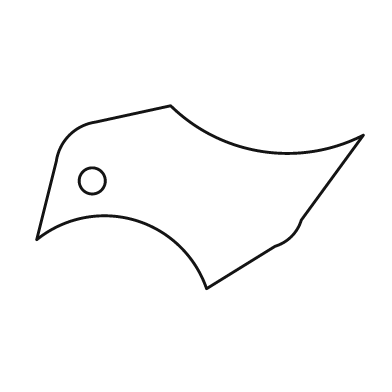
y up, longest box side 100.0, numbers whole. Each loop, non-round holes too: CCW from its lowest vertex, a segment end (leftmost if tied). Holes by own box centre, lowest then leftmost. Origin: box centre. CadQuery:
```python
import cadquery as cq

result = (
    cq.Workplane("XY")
    .moveTo(2.0, -28.0)
    .lineTo(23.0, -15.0)
    .threePointArc((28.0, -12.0), (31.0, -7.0))
    .lineTo(50.0, 19.0)
    .threePointArc((19.0, 14.0), (-9.0, 28.0))
    .lineTo(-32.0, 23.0)
    .threePointArc((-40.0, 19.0), (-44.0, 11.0))
    .lineTo(-50.0, -13.0)
    .threePointArc((-20.0, -7.0), (2.0, -28.0))
    .close()
    .moveTo(-33.0, 5.0)
    .circle(4.0)
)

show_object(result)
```